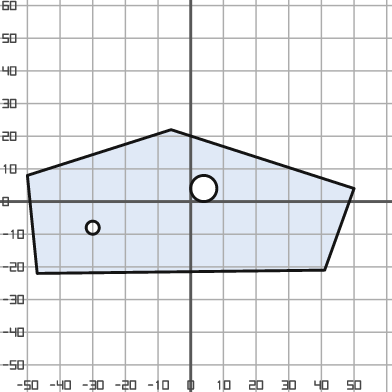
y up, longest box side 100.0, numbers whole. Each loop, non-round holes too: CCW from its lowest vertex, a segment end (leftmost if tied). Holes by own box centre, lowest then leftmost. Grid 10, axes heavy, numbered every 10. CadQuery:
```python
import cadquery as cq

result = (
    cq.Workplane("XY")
    .moveTo(-47.0, -22.0)
    .lineTo(41.0, -21.0)
    .lineTo(50.0, 4.0)
    .lineTo(-6.0, 22.0)
    .lineTo(-50.0, 8.0)
    .close()
    .moveTo(-30.0, -8.0)
    .circle(2.0)
    .moveTo(4.0, 4.0)
    .circle(4.0)
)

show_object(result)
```